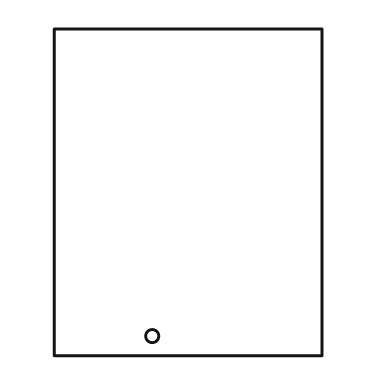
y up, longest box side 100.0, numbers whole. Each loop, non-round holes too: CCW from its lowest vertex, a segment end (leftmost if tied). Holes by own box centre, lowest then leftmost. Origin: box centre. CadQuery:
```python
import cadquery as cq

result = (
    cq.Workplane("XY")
    .moveTo(-41.0, -50.0)
    .lineTo(41.0, -50.0)
    .lineTo(41.0, 50.0)
    .lineTo(-41.0, 50.0)
    .close()
    .moveTo(-11.0, -44.0)
    .circle(2.0)
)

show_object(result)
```